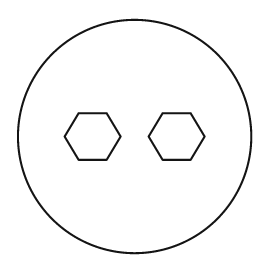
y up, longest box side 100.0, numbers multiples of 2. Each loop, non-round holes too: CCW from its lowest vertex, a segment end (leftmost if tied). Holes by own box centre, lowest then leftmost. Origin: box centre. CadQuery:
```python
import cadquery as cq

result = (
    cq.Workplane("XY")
    .moveTo(0.0, 0.0)
    .circle(50.0)
    .moveTo(-24.0, -10.0)
    .lineTo(-12.0, -10.0)
    .lineTo(-6.0, 0.0)
    .lineTo(-12.0, 10.0)
    .lineTo(-24.0, 10.0)
    .lineTo(-30.0, 0.0)
    .close()
    .moveTo(12.0, -10.0)
    .lineTo(24.0, -10.0)
    .lineTo(30.0, 0.0)
    .lineTo(24.0, 10.0)
    .lineTo(12.0, 10.0)
    .lineTo(6.0, 0.0)
    .close()
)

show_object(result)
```